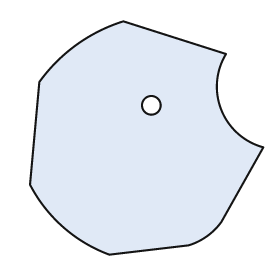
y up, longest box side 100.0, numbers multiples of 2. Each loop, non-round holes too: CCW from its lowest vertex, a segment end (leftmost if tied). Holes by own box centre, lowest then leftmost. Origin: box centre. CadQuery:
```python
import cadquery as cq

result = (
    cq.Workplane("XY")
    .moveTo(-16.0, -50.0)
    .lineTo(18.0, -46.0)
    .threePointArc((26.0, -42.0), (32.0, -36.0))
    .lineTo(50.0, -4.0)
    .threePointArc((32.0, 12.0), (34.0, 36.0))
    .lineTo(-10.0, 50.0)
    .threePointArc((-30.0, 40.0), (-46.0, 24.0))
    .lineTo(-50.0, -20.0)
    .threePointArc((-36.0, -38.0), (-16.0, -50.0))
    .close()
    .moveTo(2.0, 14.0)
    .circle(4.0)
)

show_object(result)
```